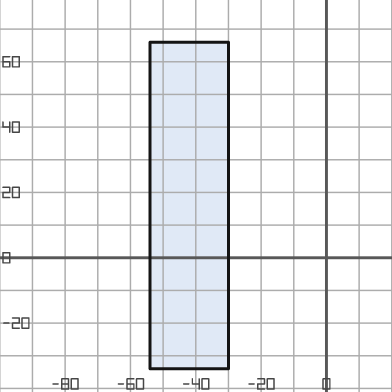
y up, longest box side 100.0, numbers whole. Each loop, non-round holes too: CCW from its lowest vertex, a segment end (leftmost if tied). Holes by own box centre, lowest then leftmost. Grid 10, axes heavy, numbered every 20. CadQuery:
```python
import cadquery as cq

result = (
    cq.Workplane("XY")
    .moveTo(-54.0, -34.0)
    .lineTo(-30.0, -34.0)
    .lineTo(-30.0, 66.0)
    .lineTo(-54.0, 66.0)
    .close()
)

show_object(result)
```